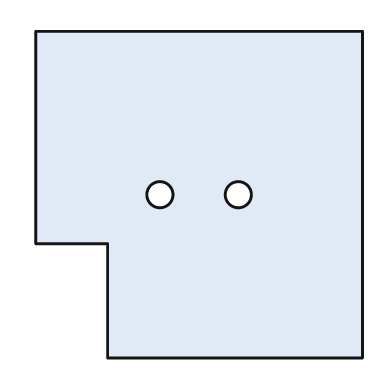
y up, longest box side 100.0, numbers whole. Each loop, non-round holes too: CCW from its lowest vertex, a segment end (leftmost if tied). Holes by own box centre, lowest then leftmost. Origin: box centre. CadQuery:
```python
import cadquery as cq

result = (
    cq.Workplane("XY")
    .moveTo(-28.0, -50.0)
    .lineTo(50.0, -50.0)
    .lineTo(50.0, 50.0)
    .lineTo(-50.0, 50.0)
    .lineTo(-50.0, -15.0)
    .lineTo(-28.0, -15.0)
    .close()
    .moveTo(-12.0, 0.0)
    .circle(4.0)
    .moveTo(12.0, 0.0)
    .circle(4.0)
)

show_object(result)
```